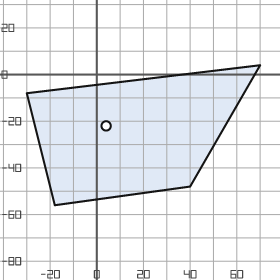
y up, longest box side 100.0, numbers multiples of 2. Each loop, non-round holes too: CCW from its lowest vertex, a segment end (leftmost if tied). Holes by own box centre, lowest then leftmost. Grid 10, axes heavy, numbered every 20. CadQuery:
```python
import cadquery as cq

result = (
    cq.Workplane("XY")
    .moveTo(-18.0, -56.0)
    .lineTo(40.0, -48.0)
    .lineTo(70.0, 4.0)
    .lineTo(-30.0, -8.0)
    .close()
    .moveTo(4.0, -22.0)
    .circle(2.0)
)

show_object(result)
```